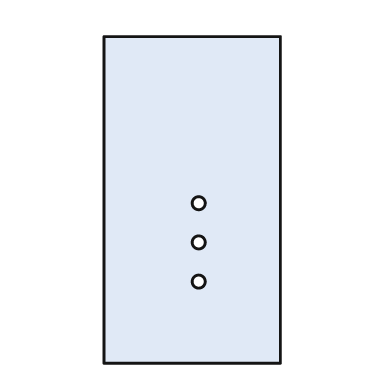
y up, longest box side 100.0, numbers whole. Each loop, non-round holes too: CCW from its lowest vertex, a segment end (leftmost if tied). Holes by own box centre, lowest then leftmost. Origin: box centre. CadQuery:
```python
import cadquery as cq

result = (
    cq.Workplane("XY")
    .moveTo(-27.0, -50.0)
    .lineTo(27.0, -50.0)
    .lineTo(27.0, 50.0)
    .lineTo(-27.0, 50.0)
    .close()
    .moveTo(2.0, -25.0)
    .circle(2.0)
    .moveTo(2.0, -13.0)
    .circle(2.0)
    .moveTo(2.0, -1.0)
    .circle(2.0)
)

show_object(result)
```